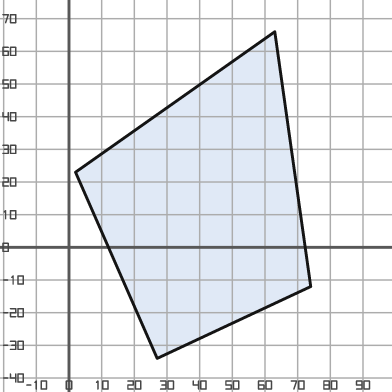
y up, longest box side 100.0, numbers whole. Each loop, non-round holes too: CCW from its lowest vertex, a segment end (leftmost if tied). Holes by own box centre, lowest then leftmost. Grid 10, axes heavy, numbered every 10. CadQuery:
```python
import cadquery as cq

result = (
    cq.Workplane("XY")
    .moveTo(27.0, -34.0)
    .lineTo(74.0, -12.0)
    .lineTo(63.0, 66.0)
    .lineTo(2.0, 23.0)
    .close()
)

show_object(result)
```